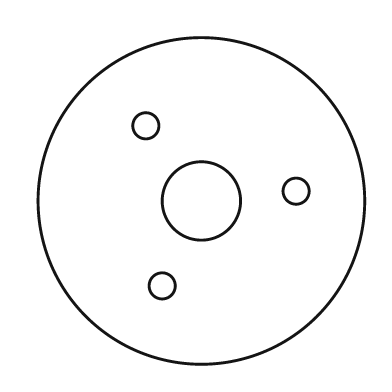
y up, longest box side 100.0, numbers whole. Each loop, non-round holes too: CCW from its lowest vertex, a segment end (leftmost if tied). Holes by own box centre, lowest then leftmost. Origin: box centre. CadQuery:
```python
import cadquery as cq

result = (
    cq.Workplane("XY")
    .moveTo(0.0, 0.0)
    .circle(50.0)
    .moveTo(-12.0, -26.0)
    .circle(4.0)
    .moveTo(0.0, 0.0)
    .circle(12.0)
    .moveTo(29.0, 3.0)
    .circle(4.0)
    .moveTo(-17.0, 23.0)
    .circle(4.0)
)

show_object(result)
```